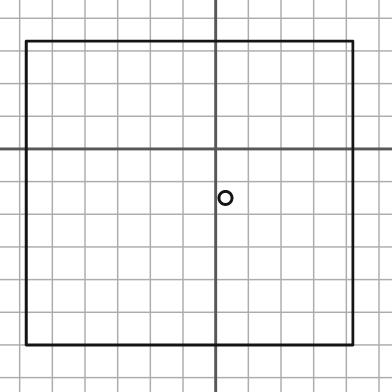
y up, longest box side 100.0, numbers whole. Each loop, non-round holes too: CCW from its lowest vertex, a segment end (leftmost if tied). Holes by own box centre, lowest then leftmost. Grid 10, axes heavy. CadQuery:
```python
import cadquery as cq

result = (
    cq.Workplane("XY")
    .moveTo(-58.0, -60.0)
    .lineTo(42.0, -60.0)
    .lineTo(42.0, 33.0)
    .lineTo(-58.0, 33.0)
    .close()
    .moveTo(3.0, -15.0)
    .circle(2.0)
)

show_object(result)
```